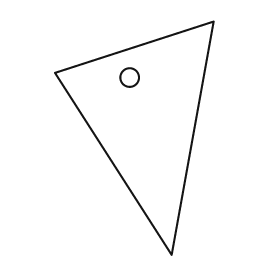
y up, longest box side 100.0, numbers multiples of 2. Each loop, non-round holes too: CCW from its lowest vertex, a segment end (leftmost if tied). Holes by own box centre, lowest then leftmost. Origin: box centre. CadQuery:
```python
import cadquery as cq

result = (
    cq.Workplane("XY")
    .moveTo(16.0, -50.0)
    .lineTo(34.0, 50.0)
    .lineTo(-34.0, 28.0)
    .close()
    .moveTo(-2.0, 26.0)
    .circle(4.0)
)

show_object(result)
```